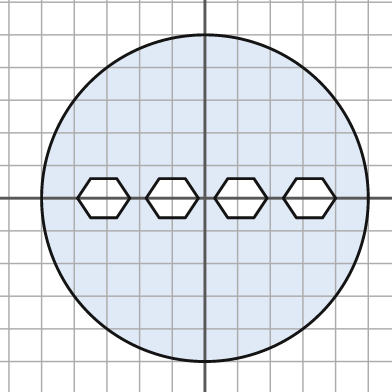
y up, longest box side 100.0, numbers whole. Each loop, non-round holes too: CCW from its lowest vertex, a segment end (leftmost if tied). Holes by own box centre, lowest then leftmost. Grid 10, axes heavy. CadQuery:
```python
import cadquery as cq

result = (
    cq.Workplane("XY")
    .moveTo(0.0, 0.0)
    .circle(50.0)
    .moveTo(-35.0, -6.0)
    .lineTo(-27.0, -6.0)
    .lineTo(-23.0, 0.0)
    .lineTo(-27.0, 6.0)
    .lineTo(-35.0, 6.0)
    .lineTo(-39.0, 0.0)
    .close()
    .moveTo(-14.0, -6.0)
    .lineTo(-6.0, -6.0)
    .lineTo(-2.0, 0.0)
    .lineTo(-6.0, 6.0)
    .lineTo(-14.0, 6.0)
    .lineTo(-18.0, 0.0)
    .close()
    .moveTo(7.0, -6.0)
    .lineTo(15.0, -6.0)
    .lineTo(19.0, 0.0)
    .lineTo(15.0, 6.0)
    .lineTo(7.0, 6.0)
    .lineTo(3.0, 0.0)
    .close()
    .moveTo(28.0, -6.0)
    .lineTo(36.0, -6.0)
    .lineTo(40.0, 0.0)
    .lineTo(36.0, 6.0)
    .lineTo(28.0, 6.0)
    .lineTo(24.0, 0.0)
    .close()
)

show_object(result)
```